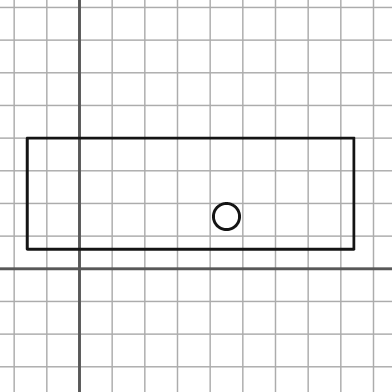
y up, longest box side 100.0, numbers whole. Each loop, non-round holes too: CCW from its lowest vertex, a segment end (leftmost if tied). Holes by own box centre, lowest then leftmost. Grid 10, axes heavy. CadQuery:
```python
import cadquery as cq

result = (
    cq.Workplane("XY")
    .moveTo(-16.0, 6.0)
    .lineTo(84.0, 6.0)
    .lineTo(84.0, 40.0)
    .lineTo(-16.0, 40.0)
    .close()
    .moveTo(45.0, 16.0)
    .circle(4.0)
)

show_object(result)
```